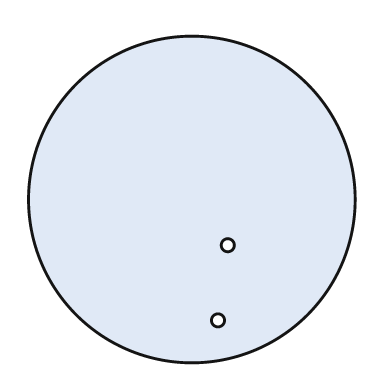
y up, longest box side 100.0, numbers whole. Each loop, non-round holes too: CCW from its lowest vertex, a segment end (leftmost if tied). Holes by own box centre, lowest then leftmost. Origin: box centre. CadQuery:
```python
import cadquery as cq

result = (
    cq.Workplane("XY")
    .moveTo(0.0, 0.0)
    .circle(50.0)
    .moveTo(8.0, -37.0)
    .circle(2.0)
    .moveTo(11.0, -14.0)
    .circle(2.0)
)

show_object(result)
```